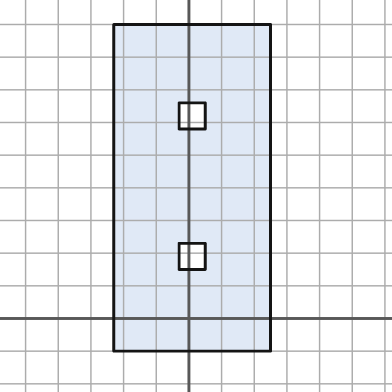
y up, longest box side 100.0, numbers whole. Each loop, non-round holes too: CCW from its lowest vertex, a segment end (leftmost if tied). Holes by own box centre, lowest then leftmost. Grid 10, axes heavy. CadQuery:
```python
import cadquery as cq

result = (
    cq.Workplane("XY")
    .moveTo(-23.0, -10.0)
    .lineTo(25.0, -10.0)
    .lineTo(25.0, 90.0)
    .lineTo(-23.0, 90.0)
    .close()
    .moveTo(-3.0, 15.0)
    .lineTo(5.0, 15.0)
    .lineTo(5.0, 23.0)
    .lineTo(-3.0, 23.0)
    .close()
    .moveTo(-3.0, 58.0)
    .lineTo(5.0, 58.0)
    .lineTo(5.0, 66.0)
    .lineTo(-3.0, 66.0)
    .close()
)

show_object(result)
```